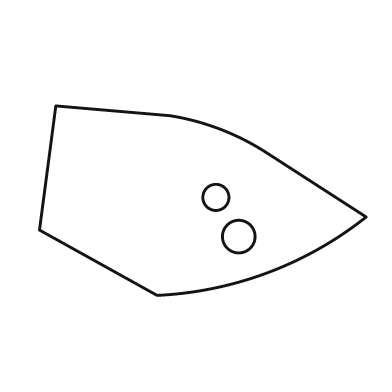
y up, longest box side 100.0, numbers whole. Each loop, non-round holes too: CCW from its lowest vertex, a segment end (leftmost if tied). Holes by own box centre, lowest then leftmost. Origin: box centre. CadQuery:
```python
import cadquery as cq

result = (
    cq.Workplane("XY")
    .moveTo(-14.0, -29.0)
    .threePointArc((20.0, -22.0), (50.0, -5.0))
    .lineTo(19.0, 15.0)
    .threePointArc((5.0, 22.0), (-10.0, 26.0))
    .lineTo(-45.0, 29.0)
    .lineTo(-50.0, -9.0)
    .close()
    .moveTo(11.0, -11.0)
    .circle(5.0)
    .moveTo(4.0, 1.0)
    .circle(4.0)
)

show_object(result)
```